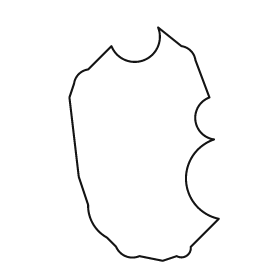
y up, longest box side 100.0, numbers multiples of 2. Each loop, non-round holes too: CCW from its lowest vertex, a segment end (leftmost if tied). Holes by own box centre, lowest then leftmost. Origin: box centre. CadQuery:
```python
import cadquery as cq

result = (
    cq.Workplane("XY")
    .moveTo(8.0, -50.0)
    .lineTo(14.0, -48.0)
    .threePointArc((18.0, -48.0), (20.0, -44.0))
    .lineTo(32.0, -32.0)
    .threePointArc((18.0, -16.0), (30.0, 2.0))
    .threePointArc((22.0, 10.0), (28.0, 20.0))
    .lineTo(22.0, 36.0)
    .threePointArc((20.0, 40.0), (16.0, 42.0))
    .lineTo(6.0, 50.0)
    .threePointArc((0.0, 36.0), (-14.0, 42.0))
    .lineTo(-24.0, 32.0)
    .threePointArc((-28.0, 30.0), (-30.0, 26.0))
    .lineTo(-32.0, 20.0)
    .lineTo(-28.0, -14.0)
    .lineTo(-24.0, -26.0)
    .threePointArc((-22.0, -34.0), (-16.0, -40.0))
    .lineTo(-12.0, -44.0)
    .threePointArc((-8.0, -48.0), (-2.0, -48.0))
    .close()
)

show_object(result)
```